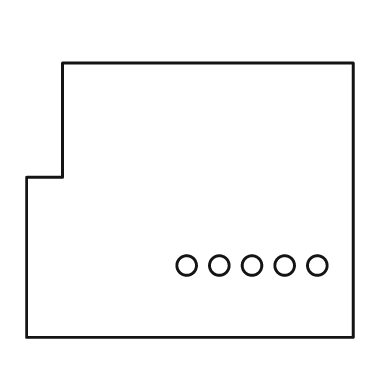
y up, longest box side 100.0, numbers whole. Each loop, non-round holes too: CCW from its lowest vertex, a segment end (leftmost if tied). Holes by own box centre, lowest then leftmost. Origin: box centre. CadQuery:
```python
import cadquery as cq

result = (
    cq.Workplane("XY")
    .moveTo(-50.0, -42.0)
    .lineTo(50.0, -42.0)
    .lineTo(50.0, 42.0)
    .lineTo(-39.0, 42.0)
    .lineTo(-39.0, 7.0)
    .lineTo(-50.0, 7.0)
    .close()
    .moveTo(-1.0, -20.0)
    .circle(3.0)
    .moveTo(9.0, -20.0)
    .circle(3.0)
    .moveTo(19.0, -20.0)
    .circle(3.0)
    .moveTo(29.0, -20.0)
    .circle(3.0)
    .moveTo(39.0, -20.0)
    .circle(3.0)
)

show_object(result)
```